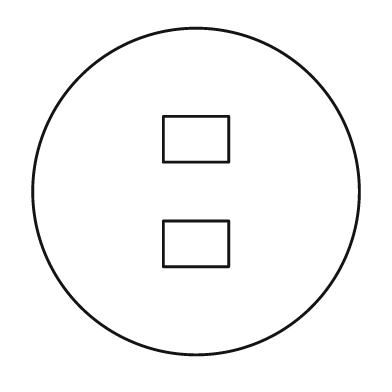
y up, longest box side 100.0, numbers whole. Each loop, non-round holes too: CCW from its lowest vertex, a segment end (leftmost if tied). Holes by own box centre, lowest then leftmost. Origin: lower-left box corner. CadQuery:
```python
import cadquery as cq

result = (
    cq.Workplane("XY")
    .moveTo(50.0, 50.0)
    .circle(50.0)
    .moveTo(40.0, 27.0)
    .lineTo(60.0, 27.0)
    .lineTo(60.0, 41.0)
    .lineTo(40.0, 41.0)
    .close()
    .moveTo(40.0, 59.0)
    .lineTo(60.0, 59.0)
    .lineTo(60.0, 73.0)
    .lineTo(40.0, 73.0)
    .close()
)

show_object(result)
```